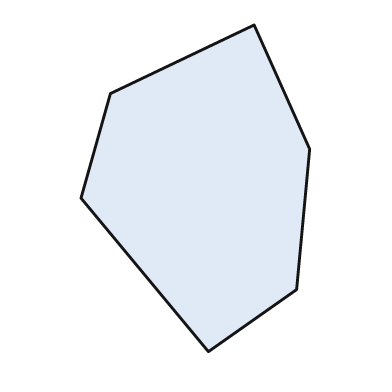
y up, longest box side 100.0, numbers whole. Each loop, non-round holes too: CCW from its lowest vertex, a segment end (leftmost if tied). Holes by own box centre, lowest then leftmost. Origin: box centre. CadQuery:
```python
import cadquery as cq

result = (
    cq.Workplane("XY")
    .moveTo(4.0, -50.0)
    .lineTo(31.0, -31.0)
    .lineTo(35.0, 12.0)
    .lineTo(18.0, 50.0)
    .lineTo(-26.0, 29.0)
    .lineTo(-35.0, -3.0)
    .close()
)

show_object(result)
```